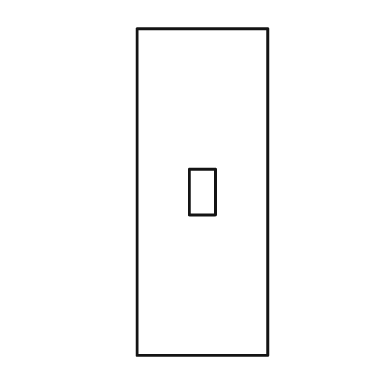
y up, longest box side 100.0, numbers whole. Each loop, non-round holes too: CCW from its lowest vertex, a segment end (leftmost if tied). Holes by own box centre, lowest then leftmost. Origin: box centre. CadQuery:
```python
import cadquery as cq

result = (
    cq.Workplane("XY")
    .moveTo(-20.0, -50.0)
    .lineTo(20.0, -50.0)
    .lineTo(20.0, 50.0)
    .lineTo(-20.0, 50.0)
    .close()
    .moveTo(-4.0, -7.0)
    .lineTo(4.0, -7.0)
    .lineTo(4.0, 7.0)
    .lineTo(-4.0, 7.0)
    .close()
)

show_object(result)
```